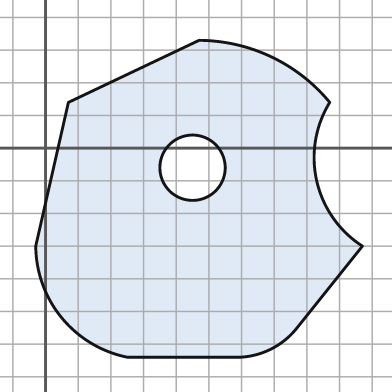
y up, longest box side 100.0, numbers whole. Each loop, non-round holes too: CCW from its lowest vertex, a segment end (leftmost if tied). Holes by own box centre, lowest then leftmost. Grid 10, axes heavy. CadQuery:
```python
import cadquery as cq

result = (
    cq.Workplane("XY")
    .moveTo(25.0, -64.0)
    .lineTo(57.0, -64.0)
    .threePointArc((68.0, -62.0), (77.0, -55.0))
    .lineTo(97.0, -30.0)
    .threePointArc((83.0, -10.0), (87.0, 14.0))
    .threePointArc((69.0, 28.0), (47.0, 33.0))
    .lineTo(7.0, 14.0)
    .lineTo(-3.0, -30.0)
    .threePointArc((5.0, -52.0), (25.0, -64.0))
    .close()
    .moveTo(45.0, -6.0)
    .circle(10.0)
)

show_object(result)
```